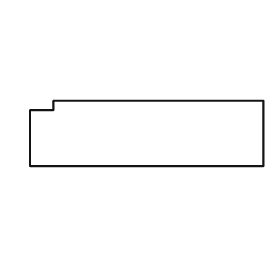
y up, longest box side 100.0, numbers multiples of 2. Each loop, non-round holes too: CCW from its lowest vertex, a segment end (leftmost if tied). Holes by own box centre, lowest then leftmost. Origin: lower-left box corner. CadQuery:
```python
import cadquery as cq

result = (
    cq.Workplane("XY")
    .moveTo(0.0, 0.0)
    .lineTo(100.0, 0.0)
    .lineTo(100.0, 28.0)
    .lineTo(10.0, 28.0)
    .lineTo(10.0, 24.0)
    .lineTo(0.0, 24.0)
    .close()
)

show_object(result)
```